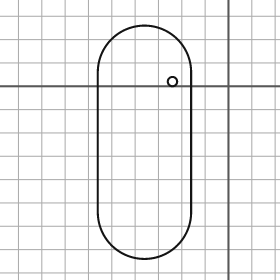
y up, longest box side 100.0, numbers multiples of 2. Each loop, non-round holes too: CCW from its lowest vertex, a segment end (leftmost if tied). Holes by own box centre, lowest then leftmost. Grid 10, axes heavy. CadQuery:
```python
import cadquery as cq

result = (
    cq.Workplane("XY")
    .moveTo(-56.0, -54.0)
    .threePointArc((-36.0, -74.0), (-16.0, -54.0))
    .lineTo(-16.0, 6.0)
    .threePointArc((-36.0, 26.0), (-56.0, 6.0))
    .close()
    .moveTo(-24.0, 2.0)
    .circle(2.0)
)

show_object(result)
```